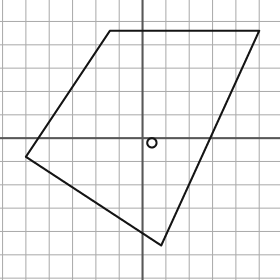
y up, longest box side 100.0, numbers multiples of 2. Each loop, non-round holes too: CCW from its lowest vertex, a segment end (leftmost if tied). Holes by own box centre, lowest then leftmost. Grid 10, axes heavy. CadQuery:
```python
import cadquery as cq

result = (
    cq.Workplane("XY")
    .moveTo(8.0, -46.0)
    .lineTo(50.0, 46.0)
    .lineTo(-14.0, 46.0)
    .lineTo(-50.0, -8.0)
    .close()
    .moveTo(4.0, -2.0)
    .circle(2.0)
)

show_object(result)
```